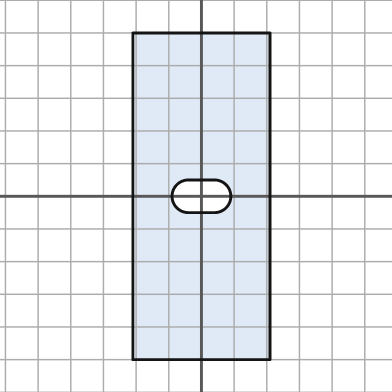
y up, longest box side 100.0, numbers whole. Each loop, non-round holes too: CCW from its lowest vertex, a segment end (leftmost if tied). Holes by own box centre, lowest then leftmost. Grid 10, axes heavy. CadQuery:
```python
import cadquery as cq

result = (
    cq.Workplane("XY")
    .moveTo(-21.0, -50.0)
    .lineTo(21.0, -50.0)
    .lineTo(21.0, 50.0)
    .lineTo(-21.0, 50.0)
    .close()
    .moveTo(-4.0, -5.0)
    .lineTo(4.0, -5.0)
    .threePointArc((9.0, 0.0), (4.0, 5.0))
    .lineTo(-4.0, 5.0)
    .threePointArc((-9.0, 0.0), (-4.0, -5.0))
    .close()
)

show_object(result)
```